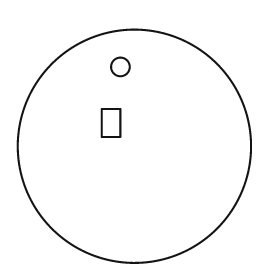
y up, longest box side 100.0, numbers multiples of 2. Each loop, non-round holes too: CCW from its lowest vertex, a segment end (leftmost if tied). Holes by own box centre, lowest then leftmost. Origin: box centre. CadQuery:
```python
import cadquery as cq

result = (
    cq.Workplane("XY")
    .moveTo(0.0, 0.0)
    .circle(50.0)
    .moveTo(-14.0, 4.0)
    .lineTo(-6.0, 4.0)
    .lineTo(-6.0, 16.0)
    .lineTo(-14.0, 16.0)
    .close()
    .moveTo(-6.0, 34.0)
    .circle(4.0)
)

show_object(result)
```